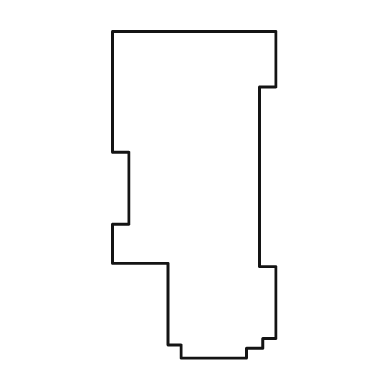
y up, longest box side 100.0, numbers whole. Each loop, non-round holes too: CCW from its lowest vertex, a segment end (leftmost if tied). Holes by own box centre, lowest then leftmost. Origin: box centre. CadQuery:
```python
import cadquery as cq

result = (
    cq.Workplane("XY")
    .moveTo(-4.0, -50.0)
    .lineTo(16.0, -50.0)
    .lineTo(16.0, -47.0)
    .lineTo(21.0, -47.0)
    .lineTo(21.0, -44.0)
    .lineTo(25.0, -44.0)
    .lineTo(25.0, -22.0)
    .lineTo(20.0, -22.0)
    .lineTo(20.0, 33.0)
    .lineTo(25.0, 33.0)
    .lineTo(25.0, 50.0)
    .lineTo(-25.0, 50.0)
    .lineTo(-25.0, 13.0)
    .lineTo(-20.0, 13.0)
    .lineTo(-20.0, -9.0)
    .lineTo(-25.0, -9.0)
    .lineTo(-25.0, -21.0)
    .lineTo(-8.0, -21.0)
    .lineTo(-8.0, -46.0)
    .lineTo(-4.0, -46.0)
    .close()
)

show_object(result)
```